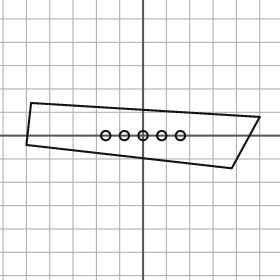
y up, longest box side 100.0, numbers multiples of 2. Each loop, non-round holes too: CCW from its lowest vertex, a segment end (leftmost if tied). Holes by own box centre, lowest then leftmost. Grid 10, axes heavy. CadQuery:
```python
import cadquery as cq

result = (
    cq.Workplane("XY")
    .moveTo(38.0, -14.0)
    .lineTo(50.0, 8.0)
    .lineTo(-48.0, 14.0)
    .lineTo(-50.0, -4.0)
    .close()
    .moveTo(-16.0, 0.0)
    .circle(2.0)
    .moveTo(-8.0, 0.0)
    .circle(2.0)
    .moveTo(0.0, 0.0)
    .circle(2.0)
    .moveTo(8.0, 0.0)
    .circle(2.0)
    .moveTo(16.0, 0.0)
    .circle(2.0)
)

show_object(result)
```